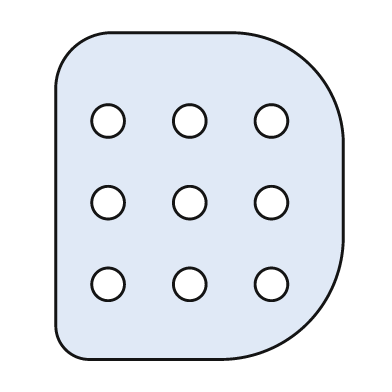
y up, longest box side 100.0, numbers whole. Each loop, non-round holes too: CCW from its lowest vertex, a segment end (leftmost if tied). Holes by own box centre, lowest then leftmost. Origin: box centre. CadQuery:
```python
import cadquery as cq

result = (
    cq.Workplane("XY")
    .moveTo(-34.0, -50.0)
    .lineTo(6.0, -50.0)
    .threePointArc((33.0, -39.0), (44.0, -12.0))
    .lineTo(44.0, 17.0)
    .threePointArc((34.0, 40.0), (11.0, 50.0))
    .lineTo(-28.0, 50.0)
    .threePointArc((-39.0, 45.0), (-44.0, 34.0))
    .lineTo(-44.0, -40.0)
    .threePointArc((-41.0, -47.0), (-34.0, -50.0))
    .close()
    .moveTo(-28.0, -27.0)
    .circle(5.0)
    .moveTo(-3.0, -27.0)
    .circle(5.0)
    .moveTo(22.0, -27.0)
    .circle(5.0)
    .moveTo(-28.0, -2.0)
    .circle(5.0)
    .moveTo(-3.0, -2.0)
    .circle(5.0)
    .moveTo(22.0, -2.0)
    .circle(5.0)
    .moveTo(-28.0, 23.0)
    .circle(5.0)
    .moveTo(-3.0, 23.0)
    .circle(5.0)
    .moveTo(22.0, 23.0)
    .circle(5.0)
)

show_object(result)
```